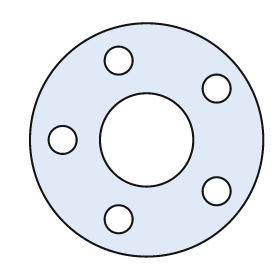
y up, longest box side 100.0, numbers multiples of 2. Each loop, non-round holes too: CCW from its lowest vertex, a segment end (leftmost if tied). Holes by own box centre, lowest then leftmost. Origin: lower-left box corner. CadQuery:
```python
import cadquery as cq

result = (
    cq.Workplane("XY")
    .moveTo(50.0, 50.0)
    .circle(50.0)
    .moveTo(38.0, 16.0)
    .circle(6.0)
    .moveTo(80.0, 28.0)
    .circle(6.0)
    .moveTo(14.0, 50.0)
    .circle(6.0)
    .moveTo(50.0, 50.0)
    .circle(20.0)
    .moveTo(80.0, 72.0)
    .circle(6.0)
    .moveTo(38.0, 84.0)
    .circle(6.0)
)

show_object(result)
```